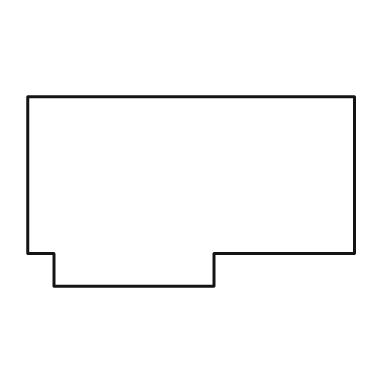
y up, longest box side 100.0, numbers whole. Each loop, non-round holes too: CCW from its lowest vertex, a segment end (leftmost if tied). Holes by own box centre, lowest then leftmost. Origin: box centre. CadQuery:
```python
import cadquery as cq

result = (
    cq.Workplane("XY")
    .moveTo(-42.0, -29.0)
    .lineTo(7.0, -29.0)
    .lineTo(7.0, -19.0)
    .lineTo(50.0, -19.0)
    .lineTo(50.0, 29.0)
    .lineTo(-50.0, 29.0)
    .lineTo(-50.0, -19.0)
    .lineTo(-42.0, -19.0)
    .close()
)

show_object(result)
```